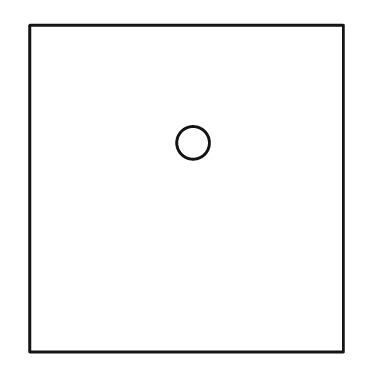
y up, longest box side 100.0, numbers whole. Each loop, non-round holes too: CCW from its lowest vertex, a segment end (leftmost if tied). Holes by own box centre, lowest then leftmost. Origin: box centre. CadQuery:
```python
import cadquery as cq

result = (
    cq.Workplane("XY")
    .moveTo(-48.0, -50.0)
    .lineTo(48.0, -50.0)
    .lineTo(48.0, 50.0)
    .lineTo(-48.0, 50.0)
    .close()
    .moveTo(2.0, 14.0)
    .circle(5.0)
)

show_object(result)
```